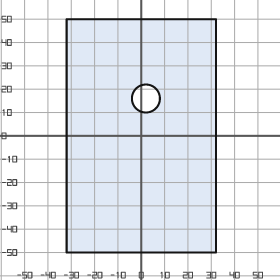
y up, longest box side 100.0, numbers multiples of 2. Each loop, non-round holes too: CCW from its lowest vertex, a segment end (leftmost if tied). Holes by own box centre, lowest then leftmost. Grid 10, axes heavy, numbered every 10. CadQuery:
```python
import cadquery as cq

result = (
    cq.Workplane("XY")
    .moveTo(-32.0, -50.0)
    .lineTo(32.0, -50.0)
    .lineTo(32.0, 50.0)
    .lineTo(-32.0, 50.0)
    .close()
    .moveTo(2.0, 16.0)
    .circle(6.0)
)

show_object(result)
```